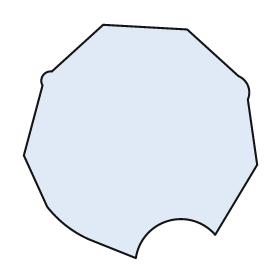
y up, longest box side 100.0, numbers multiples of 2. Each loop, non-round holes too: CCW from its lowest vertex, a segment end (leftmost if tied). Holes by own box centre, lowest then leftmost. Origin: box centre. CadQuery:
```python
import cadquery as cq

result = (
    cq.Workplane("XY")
    .moveTo(-2.0, -50.0)
    .threePointArc((12.0, -34.0), (32.0, -40.0))
    .lineTo(50.0, -10.0)
    .lineTo(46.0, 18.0)
    .threePointArc((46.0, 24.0), (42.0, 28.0))
    .lineTo(20.0, 48.0)
    .lineTo(-16.0, 50.0)
    .lineTo(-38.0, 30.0)
    .threePointArc((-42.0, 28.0), (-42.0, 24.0))
    .lineTo(-50.0, -6.0)
    .lineTo(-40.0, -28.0)
    .threePointArc((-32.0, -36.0), (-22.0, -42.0))
    .close()
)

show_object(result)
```